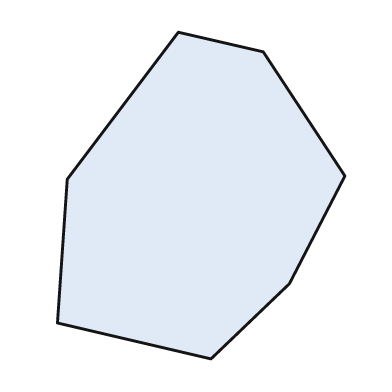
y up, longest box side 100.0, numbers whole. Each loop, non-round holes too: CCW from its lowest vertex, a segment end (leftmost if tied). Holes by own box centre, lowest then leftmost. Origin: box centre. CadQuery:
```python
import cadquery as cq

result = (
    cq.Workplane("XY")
    .moveTo(3.0, -50.0)
    .lineTo(27.0, -27.0)
    .lineTo(44.0, 6.0)
    .lineTo(19.0, 44.0)
    .lineTo(-7.0, 50.0)
    .lineTo(-41.0, 5.0)
    .lineTo(-44.0, -39.0)
    .close()
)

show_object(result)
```